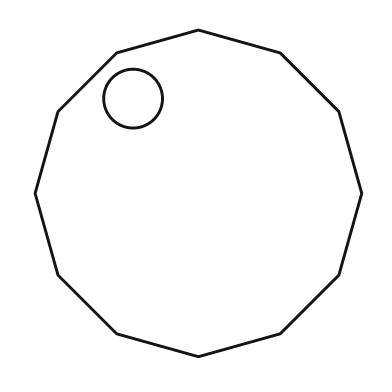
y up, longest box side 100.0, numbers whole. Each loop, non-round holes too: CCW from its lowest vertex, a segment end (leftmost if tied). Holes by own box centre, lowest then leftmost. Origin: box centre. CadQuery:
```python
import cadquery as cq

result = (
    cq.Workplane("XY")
    .moveTo(0.0, -50.0)
    .lineTo(25.0, -43.0)
    .lineTo(43.0, -25.0)
    .lineTo(50.0, 0.0)
    .lineTo(43.0, 25.0)
    .lineTo(25.0, 43.0)
    .lineTo(0.0, 50.0)
    .lineTo(-25.0, 43.0)
    .lineTo(-43.0, 25.0)
    .lineTo(-50.0, 0.0)
    .lineTo(-43.0, -25.0)
    .lineTo(-25.0, -43.0)
    .close()
    .moveTo(-20.0, 29.0)
    .circle(9.0)
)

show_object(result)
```